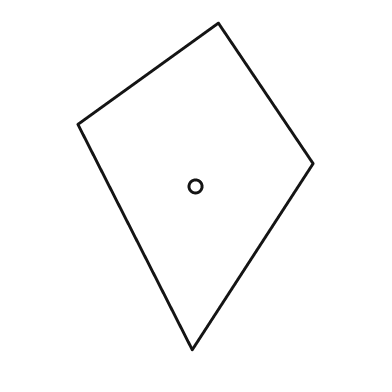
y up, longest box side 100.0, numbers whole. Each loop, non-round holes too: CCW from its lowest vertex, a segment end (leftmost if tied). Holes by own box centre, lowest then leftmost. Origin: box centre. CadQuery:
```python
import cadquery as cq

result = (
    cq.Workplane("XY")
    .moveTo(-1.0, -50.0)
    .lineTo(36.0, 7.0)
    .lineTo(7.0, 50.0)
    .lineTo(-36.0, 19.0)
    .close()
    .moveTo(0.0, 0.0)
    .circle(2.0)
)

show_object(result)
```